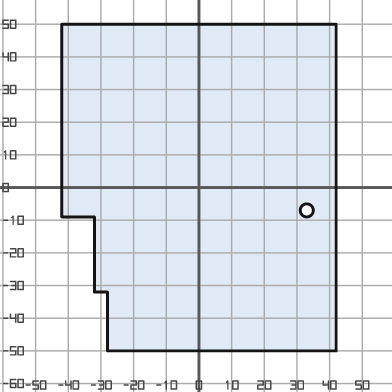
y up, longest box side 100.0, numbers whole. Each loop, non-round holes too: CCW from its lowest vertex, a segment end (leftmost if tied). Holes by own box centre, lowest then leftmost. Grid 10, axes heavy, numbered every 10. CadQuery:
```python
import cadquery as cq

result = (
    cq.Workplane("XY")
    .moveTo(-28.0, -50.0)
    .lineTo(42.0, -50.0)
    .lineTo(42.0, 50.0)
    .lineTo(-42.0, 50.0)
    .lineTo(-42.0, -9.0)
    .lineTo(-32.0, -9.0)
    .lineTo(-32.0, -32.0)
    .lineTo(-28.0, -32.0)
    .close()
    .moveTo(33.0, -7.0)
    .circle(2.0)
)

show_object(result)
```